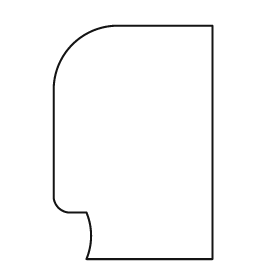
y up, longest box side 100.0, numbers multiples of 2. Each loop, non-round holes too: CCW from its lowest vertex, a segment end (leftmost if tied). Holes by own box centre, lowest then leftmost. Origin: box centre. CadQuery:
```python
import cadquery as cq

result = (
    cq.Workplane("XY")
    .moveTo(-20.0, -50.0)
    .lineTo(34.0, -50.0)
    .lineTo(34.0, 50.0)
    .lineTo(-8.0, 50.0)
    .threePointArc((-26.0, 42.0), (-34.0, 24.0))
    .lineTo(-34.0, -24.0)
    .threePointArc((-32.0, -28.0), (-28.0, -30.0))
    .lineTo(-20.0, -30.0)
    .threePointArc((-18.0, -40.0), (-20.0, -50.0))
    .close()
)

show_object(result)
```